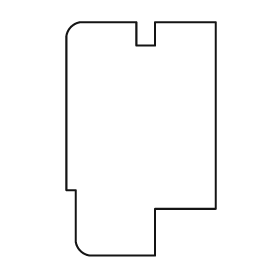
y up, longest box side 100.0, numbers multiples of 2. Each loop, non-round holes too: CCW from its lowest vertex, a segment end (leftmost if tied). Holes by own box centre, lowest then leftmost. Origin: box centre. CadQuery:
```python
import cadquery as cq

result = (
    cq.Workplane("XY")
    .moveTo(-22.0, -50.0)
    .lineTo(6.0, -50.0)
    .lineTo(6.0, -30.0)
    .lineTo(32.0, -30.0)
    .lineTo(32.0, 50.0)
    .lineTo(6.0, 50.0)
    .lineTo(6.0, 40.0)
    .lineTo(-2.0, 40.0)
    .lineTo(-2.0, 50.0)
    .lineTo(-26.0, 50.0)
    .threePointArc((-30.0, 48.0), (-32.0, 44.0))
    .lineTo(-32.0, -22.0)
    .lineTo(-28.0, -22.0)
    .lineTo(-28.0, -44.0)
    .threePointArc((-26.0, -48.0), (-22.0, -50.0))
    .close()
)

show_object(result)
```